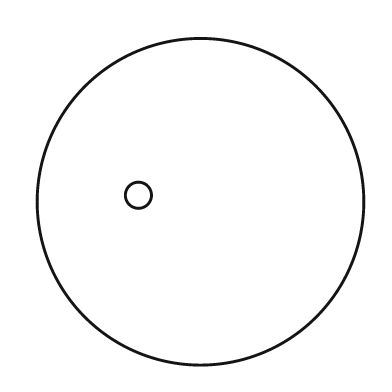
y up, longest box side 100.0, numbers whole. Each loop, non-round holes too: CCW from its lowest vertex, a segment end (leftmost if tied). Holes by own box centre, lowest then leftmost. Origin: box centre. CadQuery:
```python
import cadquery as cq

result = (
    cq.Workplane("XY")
    .moveTo(0.0, 0.0)
    .circle(50.0)
    .moveTo(-19.0, 2.0)
    .circle(4.0)
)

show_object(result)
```